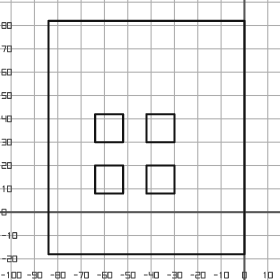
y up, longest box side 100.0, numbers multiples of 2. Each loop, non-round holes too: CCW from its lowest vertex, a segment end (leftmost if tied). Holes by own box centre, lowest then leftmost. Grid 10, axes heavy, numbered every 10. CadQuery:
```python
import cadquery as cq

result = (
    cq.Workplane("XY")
    .moveTo(-84.0, -18.0)
    .lineTo(0.0, -18.0)
    .lineTo(0.0, 82.0)
    .lineTo(-84.0, 82.0)
    .close()
    .moveTo(-64.0, 8.0)
    .lineTo(-52.0, 8.0)
    .lineTo(-52.0, 20.0)
    .lineTo(-64.0, 20.0)
    .close()
    .moveTo(-42.0, 8.0)
    .lineTo(-30.0, 8.0)
    .lineTo(-30.0, 20.0)
    .lineTo(-42.0, 20.0)
    .close()
    .moveTo(-64.0, 30.0)
    .lineTo(-52.0, 30.0)
    .lineTo(-52.0, 42.0)
    .lineTo(-64.0, 42.0)
    .close()
    .moveTo(-42.0, 30.0)
    .lineTo(-30.0, 30.0)
    .lineTo(-30.0, 42.0)
    .lineTo(-42.0, 42.0)
    .close()
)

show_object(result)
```